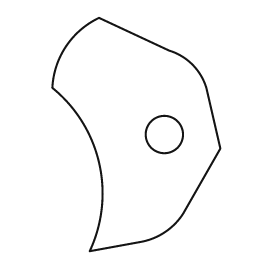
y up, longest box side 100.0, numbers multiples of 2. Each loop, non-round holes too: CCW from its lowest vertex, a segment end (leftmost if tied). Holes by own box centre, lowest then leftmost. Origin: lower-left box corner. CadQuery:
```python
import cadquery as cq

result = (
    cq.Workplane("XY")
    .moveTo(16.0, 0.0)
    .lineTo(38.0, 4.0)
    .threePointArc((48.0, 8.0), (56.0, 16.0))
    .lineTo(72.0, 44.0)
    .lineTo(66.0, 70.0)
    .threePointArc((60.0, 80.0), (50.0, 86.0))
    .lineTo(20.0, 100.0)
    .threePointArc((6.0, 88.0), (0.0, 70.0))
    .threePointArc((20.0, 38.0), (16.0, 0.0))
    .close()
    .moveTo(48.0, 50.0)
    .circle(8.0)
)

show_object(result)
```